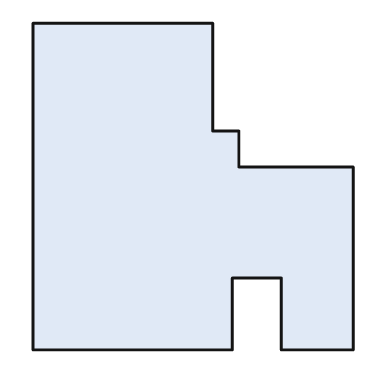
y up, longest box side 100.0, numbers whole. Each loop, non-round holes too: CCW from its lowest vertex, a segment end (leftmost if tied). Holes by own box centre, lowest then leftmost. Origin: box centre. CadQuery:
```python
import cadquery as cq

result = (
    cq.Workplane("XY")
    .moveTo(-49.0, -50.0)
    .lineTo(12.0, -50.0)
    .lineTo(12.0, -28.0)
    .lineTo(27.0, -28.0)
    .lineTo(27.0, -50.0)
    .lineTo(49.0, -50.0)
    .lineTo(49.0, 6.0)
    .lineTo(14.0, 6.0)
    .lineTo(14.0, 17.0)
    .lineTo(6.0, 17.0)
    .lineTo(6.0, 50.0)
    .lineTo(-49.0, 50.0)
    .close()
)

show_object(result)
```